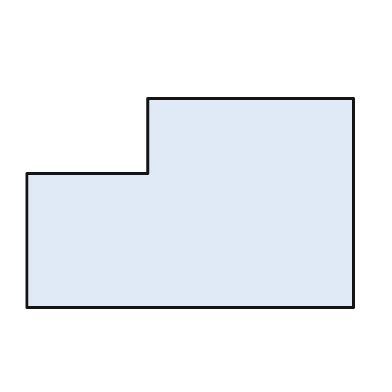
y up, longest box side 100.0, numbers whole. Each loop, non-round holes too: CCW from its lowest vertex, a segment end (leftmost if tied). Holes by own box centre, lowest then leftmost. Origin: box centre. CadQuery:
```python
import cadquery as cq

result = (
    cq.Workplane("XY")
    .moveTo(-50.0, -32.0)
    .lineTo(50.0, -32.0)
    .lineTo(50.0, 32.0)
    .lineTo(-13.0, 32.0)
    .lineTo(-13.0, 9.0)
    .lineTo(-50.0, 9.0)
    .close()
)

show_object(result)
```